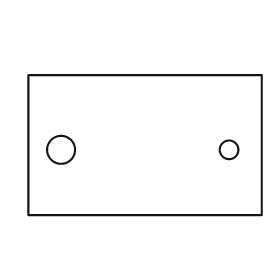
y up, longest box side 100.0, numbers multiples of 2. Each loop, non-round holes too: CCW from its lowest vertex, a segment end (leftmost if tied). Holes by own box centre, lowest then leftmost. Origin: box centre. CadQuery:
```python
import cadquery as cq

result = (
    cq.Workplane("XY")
    .moveTo(-50.0, -30.0)
    .lineTo(50.0, -30.0)
    .lineTo(50.0, 30.0)
    .lineTo(-50.0, 30.0)
    .close()
    .moveTo(-36.0, -2.0)
    .circle(6.0)
    .moveTo(36.0, -2.0)
    .circle(4.0)
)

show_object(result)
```